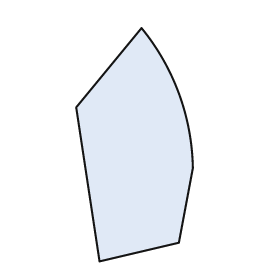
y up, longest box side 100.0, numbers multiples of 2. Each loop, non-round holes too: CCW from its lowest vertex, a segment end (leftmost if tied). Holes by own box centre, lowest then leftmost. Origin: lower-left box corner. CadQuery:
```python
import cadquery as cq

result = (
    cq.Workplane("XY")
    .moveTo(10.0, 0.0)
    .lineTo(44.0, 8.0)
    .lineTo(50.0, 40.0)
    .threePointArc((44.0, 72.0), (28.0, 100.0))
    .lineTo(0.0, 66.0)
    .close()
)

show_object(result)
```